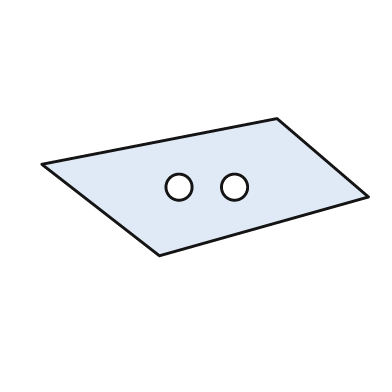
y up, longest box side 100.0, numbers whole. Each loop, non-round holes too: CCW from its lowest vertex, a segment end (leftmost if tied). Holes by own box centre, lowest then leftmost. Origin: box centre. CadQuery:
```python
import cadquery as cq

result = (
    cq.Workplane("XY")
    .moveTo(-14.0, -21.0)
    .lineTo(50.0, -3.0)
    .lineTo(22.0, 21.0)
    .lineTo(-50.0, 7.0)
    .close()
    .moveTo(-8.0, 0.0)
    .circle(4.0)
    .moveTo(9.0, 0.0)
    .circle(4.0)
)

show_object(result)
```